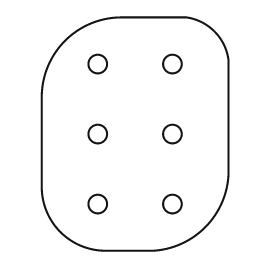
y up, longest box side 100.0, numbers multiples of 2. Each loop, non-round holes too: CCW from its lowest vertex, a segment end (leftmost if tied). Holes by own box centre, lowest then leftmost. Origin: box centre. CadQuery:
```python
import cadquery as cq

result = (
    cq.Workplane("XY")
    .moveTo(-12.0, -50.0)
    .lineTo(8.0, -50.0)
    .threePointArc((30.0, -40.0), (40.0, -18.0))
    .lineTo(40.0, 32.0)
    .threePointArc((34.0, 44.0), (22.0, 50.0))
    .lineTo(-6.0, 50.0)
    .threePointArc((-30.0, 40.0), (-40.0, 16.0))
    .lineTo(-40.0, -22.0)
    .threePointArc((-32.0, -42.0), (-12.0, -50.0))
    .close()
    .moveTo(-16.0, -30.0)
    .circle(4.0)
    .moveTo(16.0, -30.0)
    .circle(4.0)
    .moveTo(-16.0, 0.0)
    .circle(4.0)
    .moveTo(16.0, 0.0)
    .circle(4.0)
    .moveTo(-16.0, 30.0)
    .circle(4.0)
    .moveTo(16.0, 30.0)
    .circle(4.0)
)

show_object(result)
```